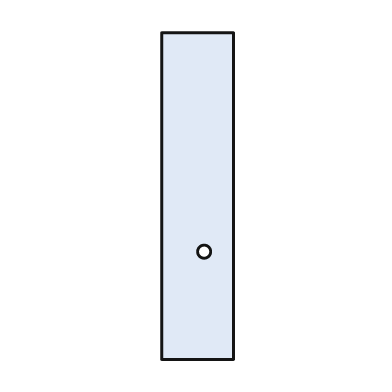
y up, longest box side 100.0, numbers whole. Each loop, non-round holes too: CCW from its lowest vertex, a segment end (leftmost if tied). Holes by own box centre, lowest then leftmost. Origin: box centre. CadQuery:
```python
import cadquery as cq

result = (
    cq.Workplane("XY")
    .moveTo(-11.0, -50.0)
    .lineTo(11.0, -50.0)
    .lineTo(11.0, 50.0)
    .lineTo(-11.0, 50.0)
    .close()
    .moveTo(2.0, -17.0)
    .circle(2.0)
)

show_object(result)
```